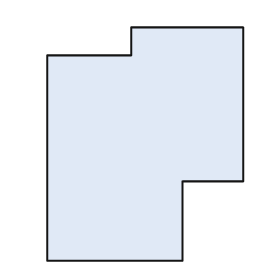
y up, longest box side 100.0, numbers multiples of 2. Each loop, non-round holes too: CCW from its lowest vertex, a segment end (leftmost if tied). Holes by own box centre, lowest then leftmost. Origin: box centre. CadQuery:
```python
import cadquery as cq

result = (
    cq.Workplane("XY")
    .moveTo(-42.0, -50.0)
    .lineTo(16.0, -50.0)
    .lineTo(16.0, -16.0)
    .lineTo(42.0, -16.0)
    .lineTo(42.0, 50.0)
    .lineTo(-6.0, 50.0)
    .lineTo(-6.0, 38.0)
    .lineTo(-42.0, 38.0)
    .close()
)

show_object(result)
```